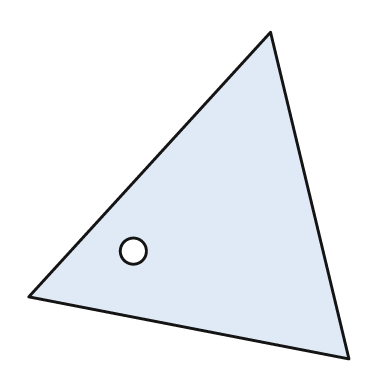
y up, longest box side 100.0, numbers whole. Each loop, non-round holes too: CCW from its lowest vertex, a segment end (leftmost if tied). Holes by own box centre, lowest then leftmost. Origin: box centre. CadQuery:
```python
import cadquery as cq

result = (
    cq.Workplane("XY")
    .moveTo(49.0, -50.0)
    .lineTo(25.0, 50.0)
    .lineTo(-49.0, -31.0)
    .close()
    .moveTo(-17.0, -17.0)
    .circle(4.0)
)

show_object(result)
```